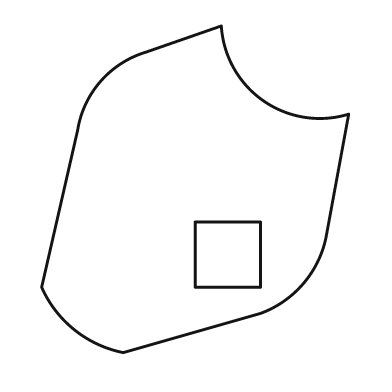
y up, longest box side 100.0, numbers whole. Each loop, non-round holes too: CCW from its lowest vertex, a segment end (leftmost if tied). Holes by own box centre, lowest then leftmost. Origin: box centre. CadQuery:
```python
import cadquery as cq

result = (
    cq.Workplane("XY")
    .moveTo(-22.0, -50.0)
    .lineTo(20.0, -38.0)
    .threePointArc((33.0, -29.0), (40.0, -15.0))
    .lineTo(47.0, 23.0)
    .threePointArc((21.0, 27.0), (8.0, 50.0))
    .lineTo(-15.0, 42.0)
    .threePointArc((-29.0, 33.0), (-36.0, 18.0))
    .lineTo(-47.0, -30.0)
    .threePointArc((-37.0, -43.0), (-22.0, -50.0))
    .close()
    .moveTo(0.0, -30.0)
    .lineTo(20.0, -30.0)
    .lineTo(20.0, -10.0)
    .lineTo(0.0, -10.0)
    .close()
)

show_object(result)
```